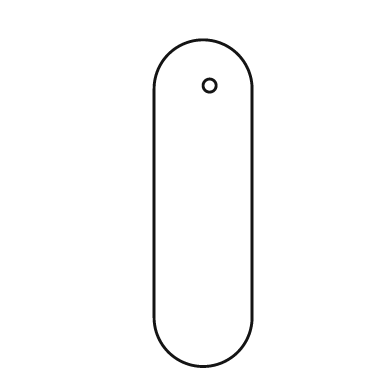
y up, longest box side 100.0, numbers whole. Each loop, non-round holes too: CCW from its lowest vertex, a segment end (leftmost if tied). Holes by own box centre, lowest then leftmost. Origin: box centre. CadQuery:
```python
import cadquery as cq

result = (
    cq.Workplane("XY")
    .moveTo(-15.0, -35.0)
    .threePointArc((0.0, -50.0), (15.0, -35.0))
    .lineTo(15.0, 35.0)
    .threePointArc((0.0, 50.0), (-15.0, 35.0))
    .close()
    .moveTo(2.0, 36.0)
    .circle(2.0)
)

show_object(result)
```